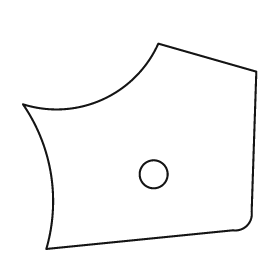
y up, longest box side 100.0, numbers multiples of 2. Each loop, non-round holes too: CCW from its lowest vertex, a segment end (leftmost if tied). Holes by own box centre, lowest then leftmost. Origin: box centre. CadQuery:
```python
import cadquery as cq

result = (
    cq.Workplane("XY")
    .moveTo(-40.0, -44.0)
    .lineTo(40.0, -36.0)
    .threePointArc((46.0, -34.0), (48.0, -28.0))
    .lineTo(50.0, 32.0)
    .lineTo(8.0, 44.0)
    .threePointArc((-16.0, 20.0), (-50.0, 18.0))
    .threePointArc((-38.0, -12.0), (-40.0, -44.0))
    .close()
    .moveTo(6.0, -12.0)
    .circle(6.0)
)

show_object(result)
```